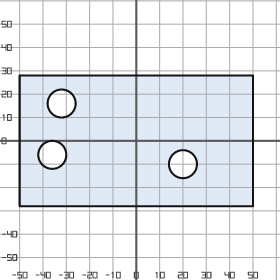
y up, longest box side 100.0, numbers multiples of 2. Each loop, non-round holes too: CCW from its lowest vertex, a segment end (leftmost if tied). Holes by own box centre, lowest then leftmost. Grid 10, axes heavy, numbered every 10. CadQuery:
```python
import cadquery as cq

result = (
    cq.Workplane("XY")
    .moveTo(-50.0, -28.0)
    .lineTo(50.0, -28.0)
    .lineTo(50.0, 28.0)
    .lineTo(-50.0, 28.0)
    .close()
    .moveTo(20.0, -10.0)
    .circle(6.0)
    .moveTo(-36.0, -6.0)
    .circle(6.0)
    .moveTo(-32.0, 16.0)
    .circle(6.0)
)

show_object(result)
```